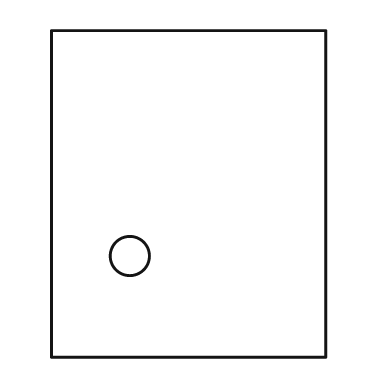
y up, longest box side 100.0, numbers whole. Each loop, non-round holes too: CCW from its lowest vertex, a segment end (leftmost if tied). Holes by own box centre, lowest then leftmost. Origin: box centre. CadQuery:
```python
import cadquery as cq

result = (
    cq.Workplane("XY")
    .moveTo(-42.0, -50.0)
    .lineTo(42.0, -50.0)
    .lineTo(42.0, 50.0)
    .lineTo(-42.0, 50.0)
    .close()
    .moveTo(-18.0, -19.0)
    .circle(6.0)
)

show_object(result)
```